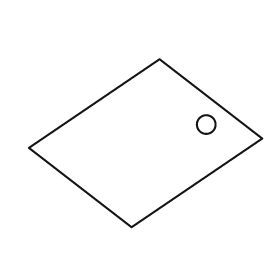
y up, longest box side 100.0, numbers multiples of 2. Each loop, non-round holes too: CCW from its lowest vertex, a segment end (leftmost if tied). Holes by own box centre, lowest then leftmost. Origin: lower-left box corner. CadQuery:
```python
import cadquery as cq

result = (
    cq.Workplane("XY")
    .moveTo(44.0, 0.0)
    .lineTo(100.0, 38.0)
    .lineTo(56.0, 72.0)
    .lineTo(0.0, 34.0)
    .close()
    .moveTo(76.0, 44.0)
    .circle(4.0)
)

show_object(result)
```